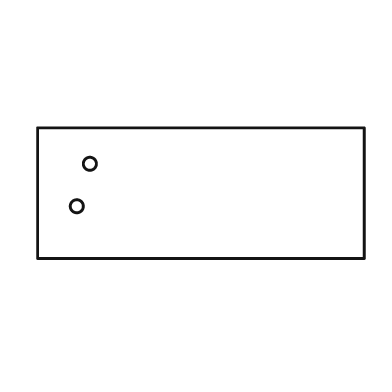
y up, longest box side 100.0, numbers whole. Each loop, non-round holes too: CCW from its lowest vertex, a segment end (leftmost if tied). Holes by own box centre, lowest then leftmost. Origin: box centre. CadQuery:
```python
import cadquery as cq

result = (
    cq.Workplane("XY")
    .moveTo(-50.0, -20.0)
    .lineTo(50.0, -20.0)
    .lineTo(50.0, 20.0)
    .lineTo(-50.0, 20.0)
    .close()
    .moveTo(-38.0, -4.0)
    .circle(2.0)
    .moveTo(-34.0, 9.0)
    .circle(2.0)
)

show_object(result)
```